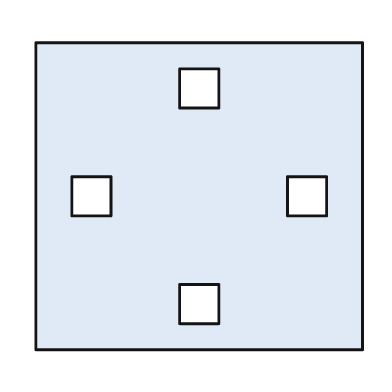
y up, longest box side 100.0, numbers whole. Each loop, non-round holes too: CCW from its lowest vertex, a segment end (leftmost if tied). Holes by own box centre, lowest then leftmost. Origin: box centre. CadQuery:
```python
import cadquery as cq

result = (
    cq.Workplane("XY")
    .moveTo(-50.0, -47.0)
    .lineTo(50.0, -47.0)
    .lineTo(50.0, 47.0)
    .lineTo(-50.0, 47.0)
    .close()
    .moveTo(-6.0, -39.0)
    .lineTo(6.0, -39.0)
    .lineTo(6.0, -27.0)
    .lineTo(-6.0, -27.0)
    .close()
    .moveTo(-39.0, -6.0)
    .lineTo(-27.0, -6.0)
    .lineTo(-27.0, 6.0)
    .lineTo(-39.0, 6.0)
    .close()
    .moveTo(27.0, -6.0)
    .lineTo(39.0, -6.0)
    .lineTo(39.0, 6.0)
    .lineTo(27.0, 6.0)
    .close()
    .moveTo(-6.0, 27.0)
    .lineTo(6.0, 27.0)
    .lineTo(6.0, 39.0)
    .lineTo(-6.0, 39.0)
    .close()
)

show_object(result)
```